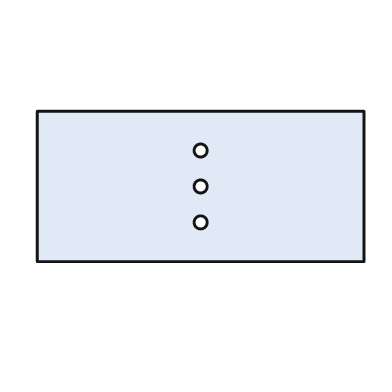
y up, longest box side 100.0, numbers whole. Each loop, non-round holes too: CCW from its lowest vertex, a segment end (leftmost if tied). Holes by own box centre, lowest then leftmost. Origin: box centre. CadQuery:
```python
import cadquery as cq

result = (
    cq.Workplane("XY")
    .moveTo(-50.0, -23.0)
    .lineTo(50.0, -23.0)
    .lineTo(50.0, 23.0)
    .lineTo(-50.0, 23.0)
    .close()
    .moveTo(0.0, -11.0)
    .circle(2.0)
    .moveTo(0.0, 0.0)
    .circle(2.0)
    .moveTo(0.0, 11.0)
    .circle(2.0)
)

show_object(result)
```